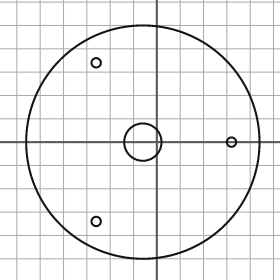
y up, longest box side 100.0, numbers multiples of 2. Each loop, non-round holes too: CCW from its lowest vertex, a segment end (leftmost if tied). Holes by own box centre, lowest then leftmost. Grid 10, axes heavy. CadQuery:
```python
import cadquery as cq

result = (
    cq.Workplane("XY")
    .moveTo(-6.0, 0.0)
    .circle(50.0)
    .moveTo(-26.0, -34.0)
    .circle(2.0)
    .moveTo(-6.0, 0.0)
    .circle(8.0)
    .moveTo(32.0, 0.0)
    .circle(2.0)
    .moveTo(-26.0, 34.0)
    .circle(2.0)
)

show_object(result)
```